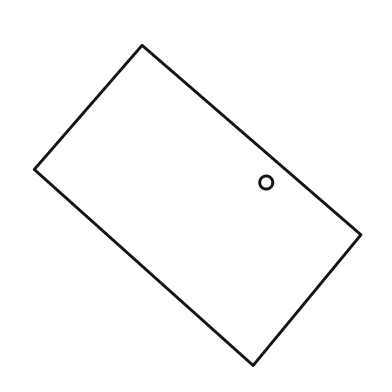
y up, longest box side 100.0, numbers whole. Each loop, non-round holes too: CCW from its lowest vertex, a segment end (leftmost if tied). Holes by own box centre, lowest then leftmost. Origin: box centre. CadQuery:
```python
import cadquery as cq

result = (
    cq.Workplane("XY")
    .moveTo(17.0, -49.0)
    .lineTo(50.0, -9.0)
    .lineTo(-17.0, 49.0)
    .lineTo(-50.0, 11.0)
    .close()
    .moveTo(21.0, 7.0)
    .circle(2.0)
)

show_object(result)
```